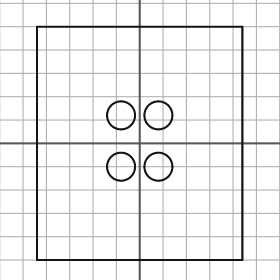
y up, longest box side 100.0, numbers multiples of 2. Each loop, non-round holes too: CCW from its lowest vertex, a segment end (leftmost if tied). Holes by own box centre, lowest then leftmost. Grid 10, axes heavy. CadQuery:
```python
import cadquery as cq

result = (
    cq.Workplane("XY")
    .moveTo(-44.0, -50.0)
    .lineTo(44.0, -50.0)
    .lineTo(44.0, 50.0)
    .lineTo(-44.0, 50.0)
    .close()
    .moveTo(-8.0, -10.0)
    .circle(6.0)
    .moveTo(8.0, -10.0)
    .circle(6.0)
    .moveTo(-8.0, 12.0)
    .circle(6.0)
    .moveTo(8.0, 12.0)
    .circle(6.0)
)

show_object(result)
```